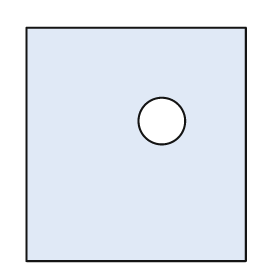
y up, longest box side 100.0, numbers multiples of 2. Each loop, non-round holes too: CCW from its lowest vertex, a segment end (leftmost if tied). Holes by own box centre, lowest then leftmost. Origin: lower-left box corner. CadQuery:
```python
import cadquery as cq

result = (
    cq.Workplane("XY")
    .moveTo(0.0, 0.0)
    .lineTo(94.0, 0.0)
    .lineTo(94.0, 100.0)
    .lineTo(0.0, 100.0)
    .close()
    .moveTo(58.0, 60.0)
    .circle(10.0)
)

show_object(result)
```